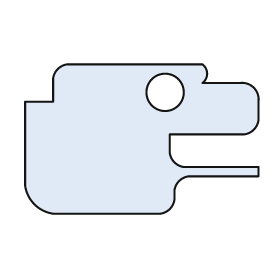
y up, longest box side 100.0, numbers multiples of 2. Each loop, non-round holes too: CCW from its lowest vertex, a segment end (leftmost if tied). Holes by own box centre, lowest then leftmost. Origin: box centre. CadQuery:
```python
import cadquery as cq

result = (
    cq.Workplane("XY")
    .moveTo(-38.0, -32.0)
    .lineTo(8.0, -32.0)
    .threePointArc((12.0, -30.0), (14.0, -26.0))
    .lineTo(14.0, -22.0)
    .threePointArc((16.0, -18.0), (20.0, -16.0))
    .lineTo(50.0, -16.0)
    .lineTo(50.0, -12.0)
    .lineTo(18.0, -12.0)
    .threePointArc((14.0, -10.0), (12.0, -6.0))
    .lineTo(12.0, 2.0)
    .lineTo(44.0, 2.0)
    .threePointArc((48.0, 4.0), (50.0, 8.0))
    .lineTo(50.0, 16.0)
    .threePointArc((48.0, 22.0), (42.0, 24.0))
    .lineTo(26.0, 24.0)
    .threePointArc((28.0, 28.0), (26.0, 32.0))
    .lineTo(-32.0, 32.0)
    .threePointArc((-36.0, 30.0), (-38.0, 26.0))
    .lineTo(-38.0, 16.0)
    .lineTo(-50.0, 16.0)
    .lineTo(-50.0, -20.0)
    .threePointArc((-46.0, -28.0), (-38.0, -32.0))
    .close()
    .moveTo(10.0, 20.0)
    .circle(8.0)
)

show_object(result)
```